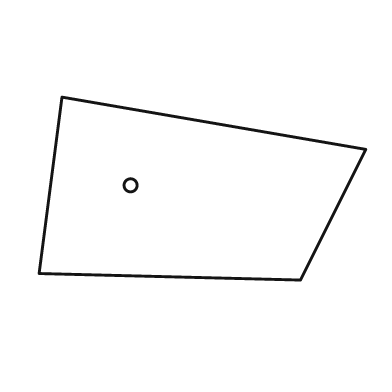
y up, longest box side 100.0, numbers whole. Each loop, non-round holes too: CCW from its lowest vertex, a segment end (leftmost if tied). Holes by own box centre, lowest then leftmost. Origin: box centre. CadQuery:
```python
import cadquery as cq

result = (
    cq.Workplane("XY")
    .moveTo(30.0, -28.0)
    .lineTo(50.0, 12.0)
    .lineTo(-43.0, 28.0)
    .lineTo(-50.0, -26.0)
    .close()
    .moveTo(-22.0, 1.0)
    .circle(2.0)
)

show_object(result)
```